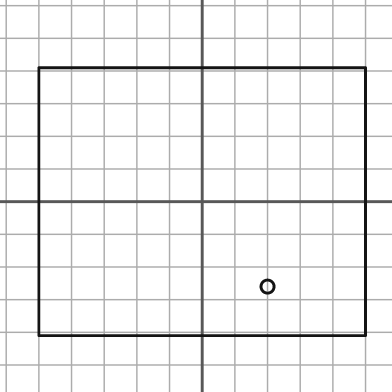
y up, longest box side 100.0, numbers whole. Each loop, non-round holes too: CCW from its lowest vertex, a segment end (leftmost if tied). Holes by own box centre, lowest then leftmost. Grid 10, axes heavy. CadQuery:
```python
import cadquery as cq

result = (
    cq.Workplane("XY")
    .moveTo(-50.0, -41.0)
    .lineTo(50.0, -41.0)
    .lineTo(50.0, 41.0)
    .lineTo(-50.0, 41.0)
    .close()
    .moveTo(20.0, -26.0)
    .circle(2.0)
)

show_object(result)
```